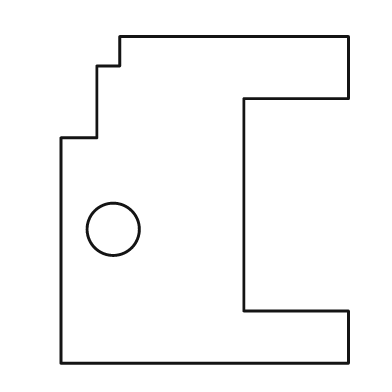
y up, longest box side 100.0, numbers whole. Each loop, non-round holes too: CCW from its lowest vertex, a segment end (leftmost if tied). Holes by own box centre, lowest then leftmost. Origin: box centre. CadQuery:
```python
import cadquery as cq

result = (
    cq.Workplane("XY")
    .moveTo(-44.0, -50.0)
    .lineTo(44.0, -50.0)
    .lineTo(44.0, -34.0)
    .lineTo(12.0, -34.0)
    .lineTo(12.0, 31.0)
    .lineTo(44.0, 31.0)
    .lineTo(44.0, 50.0)
    .lineTo(-26.0, 50.0)
    .lineTo(-26.0, 41.0)
    .lineTo(-33.0, 41.0)
    .lineTo(-33.0, 19.0)
    .lineTo(-44.0, 19.0)
    .close()
    .moveTo(-28.0, -9.0)
    .circle(8.0)
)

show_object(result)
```